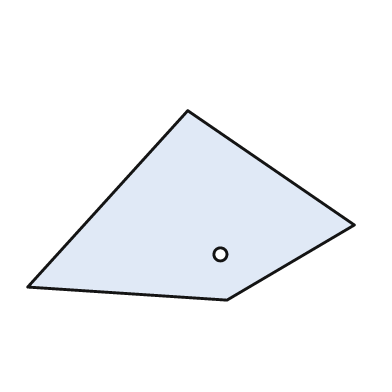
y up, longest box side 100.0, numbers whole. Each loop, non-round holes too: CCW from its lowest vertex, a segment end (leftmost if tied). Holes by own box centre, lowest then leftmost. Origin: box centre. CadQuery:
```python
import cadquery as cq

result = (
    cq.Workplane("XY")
    .moveTo(11.0, -29.0)
    .lineTo(50.0, -6.0)
    .lineTo(-1.0, 29.0)
    .lineTo(-50.0, -25.0)
    .close()
    .moveTo(9.0, -15.0)
    .circle(2.0)
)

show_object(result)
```